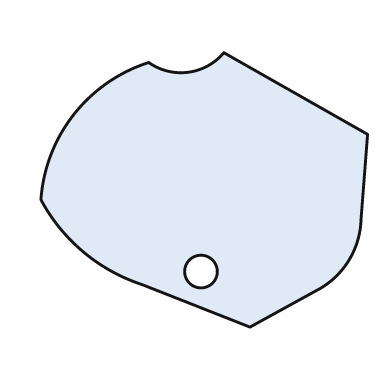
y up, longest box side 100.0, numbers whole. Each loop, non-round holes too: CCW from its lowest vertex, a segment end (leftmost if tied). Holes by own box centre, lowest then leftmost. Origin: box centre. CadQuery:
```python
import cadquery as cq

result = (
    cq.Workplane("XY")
    .moveTo(14.0, -42.0)
    .lineTo(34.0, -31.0)
    .threePointArc((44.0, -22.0), (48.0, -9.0))
    .lineTo(50.0, 17.0)
    .lineTo(6.0, 42.0)
    .threePointArc((-5.0, 36.0), (-17.0, 39.0))
    .threePointArc((-40.0, 23.0), (-50.0, -3.0))
    .threePointArc((-37.0, -19.0), (-19.0, -29.0))
    .close()
    .moveTo(-1.0, -25.0)
    .circle(5.0)
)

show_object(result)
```